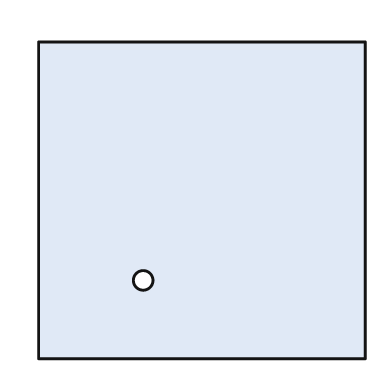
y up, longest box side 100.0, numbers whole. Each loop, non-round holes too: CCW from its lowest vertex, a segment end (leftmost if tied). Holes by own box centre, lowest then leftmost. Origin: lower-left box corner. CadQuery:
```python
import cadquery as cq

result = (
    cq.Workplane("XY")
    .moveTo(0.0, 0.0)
    .lineTo(100.0, 0.0)
    .lineTo(100.0, 97.0)
    .lineTo(0.0, 97.0)
    .close()
    .moveTo(32.0, 24.0)
    .circle(3.0)
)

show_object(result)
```